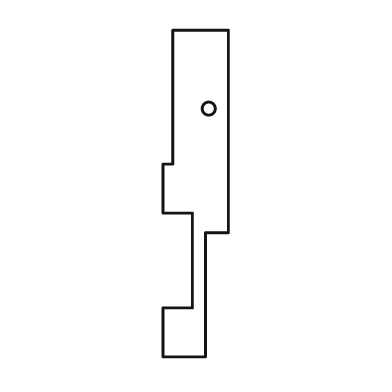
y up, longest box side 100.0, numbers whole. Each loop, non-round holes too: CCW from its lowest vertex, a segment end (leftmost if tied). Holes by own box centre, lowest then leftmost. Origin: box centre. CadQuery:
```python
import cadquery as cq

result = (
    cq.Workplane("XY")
    .moveTo(-10.0, -50.0)
    .lineTo(3.0, -50.0)
    .lineTo(3.0, -12.0)
    .lineTo(10.0, -12.0)
    .lineTo(10.0, 50.0)
    .lineTo(-7.0, 50.0)
    .lineTo(-7.0, 9.0)
    .lineTo(-10.0, 9.0)
    .lineTo(-10.0, -6.0)
    .lineTo(-1.0, -6.0)
    .lineTo(-1.0, -35.0)
    .lineTo(-10.0, -35.0)
    .close()
    .moveTo(4.0, 26.0)
    .circle(2.0)
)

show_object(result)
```